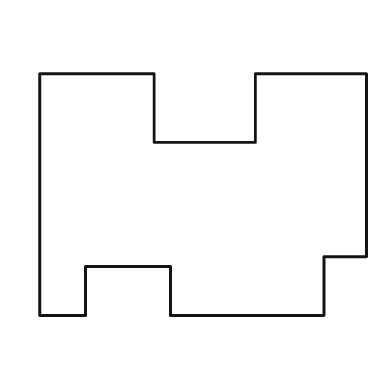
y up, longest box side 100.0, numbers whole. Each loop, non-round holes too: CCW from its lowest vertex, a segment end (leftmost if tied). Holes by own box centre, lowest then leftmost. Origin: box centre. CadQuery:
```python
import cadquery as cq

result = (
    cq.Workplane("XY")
    .moveTo(-50.0, -37.0)
    .lineTo(-36.0, -37.0)
    .lineTo(-36.0, -22.0)
    .lineTo(-10.0, -22.0)
    .lineTo(-10.0, -37.0)
    .lineTo(37.0, -37.0)
    .lineTo(37.0, -19.0)
    .lineTo(50.0, -19.0)
    .lineTo(50.0, 37.0)
    .lineTo(16.0, 37.0)
    .lineTo(16.0, 16.0)
    .lineTo(-15.0, 16.0)
    .lineTo(-15.0, 37.0)
    .lineTo(-50.0, 37.0)
    .close()
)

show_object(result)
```